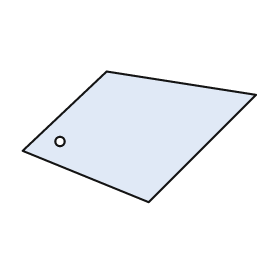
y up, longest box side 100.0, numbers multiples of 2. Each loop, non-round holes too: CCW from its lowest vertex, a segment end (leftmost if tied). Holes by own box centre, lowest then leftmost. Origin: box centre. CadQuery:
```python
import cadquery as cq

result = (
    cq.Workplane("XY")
    .moveTo(4.0, -28.0)
    .lineTo(50.0, 18.0)
    .lineTo(-14.0, 28.0)
    .lineTo(-50.0, -6.0)
    .close()
    .moveTo(-34.0, -2.0)
    .circle(2.0)
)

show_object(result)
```